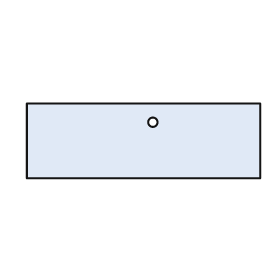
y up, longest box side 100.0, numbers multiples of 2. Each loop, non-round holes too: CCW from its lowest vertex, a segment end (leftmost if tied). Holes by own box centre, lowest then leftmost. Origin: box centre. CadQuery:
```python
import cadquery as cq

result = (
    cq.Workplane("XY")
    .moveTo(-50.0, -16.0)
    .lineTo(50.0, -16.0)
    .lineTo(50.0, 16.0)
    .lineTo(-50.0, 16.0)
    .close()
    .moveTo(4.0, 8.0)
    .circle(2.0)
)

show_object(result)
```